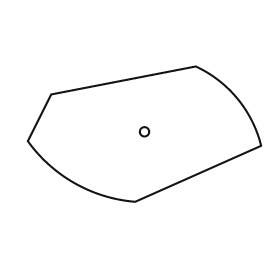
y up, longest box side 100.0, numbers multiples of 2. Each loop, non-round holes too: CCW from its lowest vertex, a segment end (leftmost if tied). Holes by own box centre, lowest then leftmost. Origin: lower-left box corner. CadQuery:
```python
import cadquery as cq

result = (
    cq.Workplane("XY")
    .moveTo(46.0, 0.0)
    .lineTo(100.0, 24.0)
    .threePointArc((90.0, 44.0), (72.0, 58.0))
    .lineTo(10.0, 46.0)
    .lineTo(0.0, 26.0)
    .threePointArc((20.0, 8.0), (46.0, 0.0))
    .close()
    .moveTo(50.0, 30.0)
    .circle(2.0)
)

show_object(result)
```